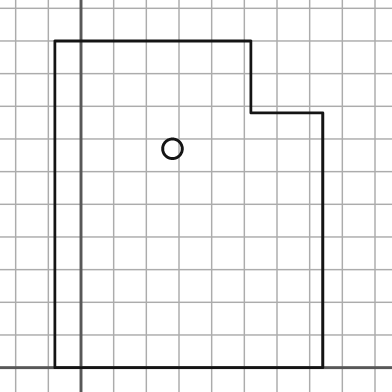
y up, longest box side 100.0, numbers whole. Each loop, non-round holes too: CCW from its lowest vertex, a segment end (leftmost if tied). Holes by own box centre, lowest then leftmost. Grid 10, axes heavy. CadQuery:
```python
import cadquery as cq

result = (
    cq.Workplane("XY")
    .moveTo(-8.0, 0.0)
    .lineTo(74.0, 0.0)
    .lineTo(74.0, 78.0)
    .lineTo(52.0, 78.0)
    .lineTo(52.0, 100.0)
    .lineTo(-8.0, 100.0)
    .close()
    .moveTo(28.0, 67.0)
    .circle(3.0)
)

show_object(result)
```